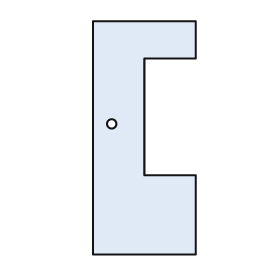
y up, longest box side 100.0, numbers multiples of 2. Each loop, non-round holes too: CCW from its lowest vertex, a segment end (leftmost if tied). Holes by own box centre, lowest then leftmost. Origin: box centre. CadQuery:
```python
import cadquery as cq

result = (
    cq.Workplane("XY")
    .moveTo(-22.0, -50.0)
    .lineTo(22.0, -50.0)
    .lineTo(22.0, -16.0)
    .lineTo(0.0, -16.0)
    .lineTo(0.0, 34.0)
    .lineTo(22.0, 34.0)
    .lineTo(22.0, 50.0)
    .lineTo(-22.0, 50.0)
    .close()
    .moveTo(-14.0, 6.0)
    .circle(2.0)
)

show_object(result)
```